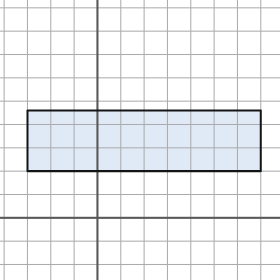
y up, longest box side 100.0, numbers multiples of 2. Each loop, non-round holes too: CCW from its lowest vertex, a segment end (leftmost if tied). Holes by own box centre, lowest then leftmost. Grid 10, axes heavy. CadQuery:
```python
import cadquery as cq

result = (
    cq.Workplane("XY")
    .moveTo(-30.0, 20.0)
    .lineTo(70.0, 20.0)
    .lineTo(70.0, 46.0)
    .lineTo(-30.0, 46.0)
    .close()
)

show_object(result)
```